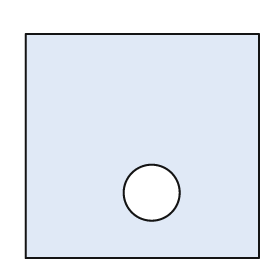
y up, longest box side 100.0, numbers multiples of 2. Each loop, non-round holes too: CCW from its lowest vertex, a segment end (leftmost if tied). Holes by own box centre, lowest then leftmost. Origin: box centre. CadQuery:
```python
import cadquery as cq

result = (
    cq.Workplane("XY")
    .moveTo(-50.0, -48.0)
    .lineTo(50.0, -48.0)
    .lineTo(50.0, 48.0)
    .lineTo(-50.0, 48.0)
    .close()
    .moveTo(4.0, -20.0)
    .circle(12.0)
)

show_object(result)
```